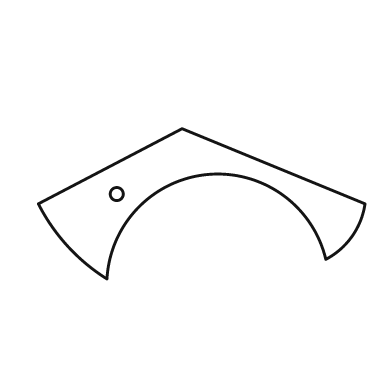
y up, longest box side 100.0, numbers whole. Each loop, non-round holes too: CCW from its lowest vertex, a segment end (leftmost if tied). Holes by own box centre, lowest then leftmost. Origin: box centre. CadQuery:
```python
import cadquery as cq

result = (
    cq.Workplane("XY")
    .moveTo(-29.0, -23.0)
    .threePointArc((2.0, 9.0), (38.0, -17.0))
    .threePointArc((46.0, -10.0), (50.0, 0.0))
    .lineTo(-6.0, 23.0)
    .lineTo(-50.0, 0.0)
    .threePointArc((-41.0, -13.0), (-29.0, -23.0))
    .close()
    .moveTo(-26.0, 3.0)
    .circle(2.0)
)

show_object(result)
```